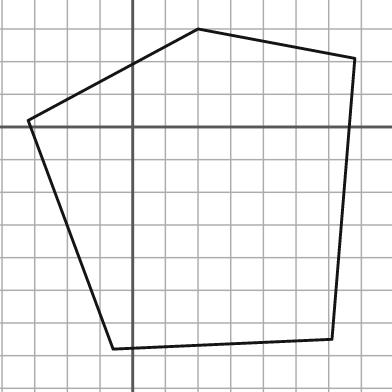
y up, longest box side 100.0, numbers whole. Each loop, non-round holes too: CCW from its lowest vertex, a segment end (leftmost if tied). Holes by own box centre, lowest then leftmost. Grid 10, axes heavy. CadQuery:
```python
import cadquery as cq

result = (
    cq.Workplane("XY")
    .moveTo(-6.0, -68.0)
    .lineTo(61.0, -65.0)
    .lineTo(68.0, 21.0)
    .lineTo(20.0, 30.0)
    .lineTo(-32.0, 2.0)
    .close()
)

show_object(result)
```